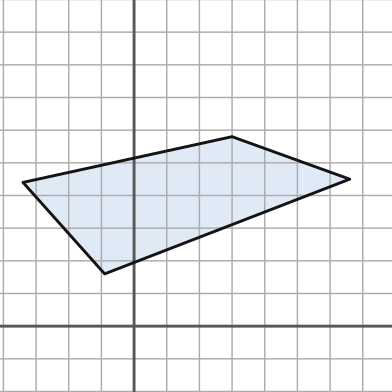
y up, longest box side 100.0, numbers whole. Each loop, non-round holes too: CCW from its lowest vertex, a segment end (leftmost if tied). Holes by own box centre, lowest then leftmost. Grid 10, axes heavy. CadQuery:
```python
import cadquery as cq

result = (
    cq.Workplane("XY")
    .moveTo(-9.0, 16.0)
    .lineTo(66.0, 45.0)
    .lineTo(30.0, 58.0)
    .lineTo(-34.0, 44.0)
    .close()
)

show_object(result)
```